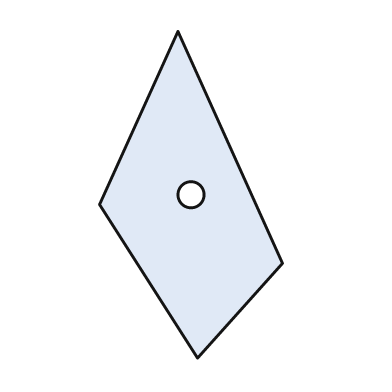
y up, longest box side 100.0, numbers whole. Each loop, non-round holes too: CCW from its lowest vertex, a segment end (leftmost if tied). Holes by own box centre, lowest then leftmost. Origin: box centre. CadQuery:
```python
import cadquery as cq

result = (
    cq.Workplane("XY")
    .moveTo(2.0, -50.0)
    .lineTo(28.0, -21.0)
    .lineTo(-4.0, 50.0)
    .lineTo(-28.0, -3.0)
    .close()
    .moveTo(0.0, 0.0)
    .circle(4.0)
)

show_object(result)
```